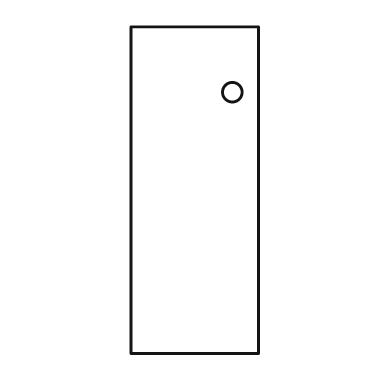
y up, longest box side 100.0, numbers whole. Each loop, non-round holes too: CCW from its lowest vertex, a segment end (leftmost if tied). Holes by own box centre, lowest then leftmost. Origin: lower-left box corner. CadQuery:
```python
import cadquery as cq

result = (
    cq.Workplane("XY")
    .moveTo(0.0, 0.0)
    .lineTo(39.0, 0.0)
    .lineTo(39.0, 100.0)
    .lineTo(0.0, 100.0)
    .close()
    .moveTo(31.0, 80.0)
    .circle(3.0)
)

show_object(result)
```